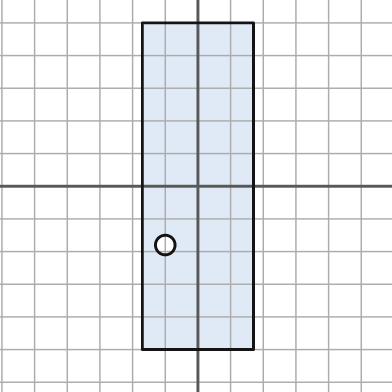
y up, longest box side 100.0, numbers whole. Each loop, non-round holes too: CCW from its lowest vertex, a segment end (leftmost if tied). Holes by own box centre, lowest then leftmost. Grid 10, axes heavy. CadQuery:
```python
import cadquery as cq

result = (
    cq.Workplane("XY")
    .moveTo(-17.0, -50.0)
    .lineTo(17.0, -50.0)
    .lineTo(17.0, 50.0)
    .lineTo(-17.0, 50.0)
    .close()
    .moveTo(-10.0, -18.0)
    .circle(3.0)
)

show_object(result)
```